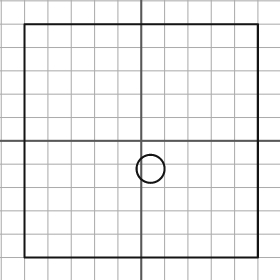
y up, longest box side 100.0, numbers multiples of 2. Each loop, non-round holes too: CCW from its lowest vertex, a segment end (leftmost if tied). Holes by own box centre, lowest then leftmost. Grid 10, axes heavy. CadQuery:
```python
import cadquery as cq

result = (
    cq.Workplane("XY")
    .moveTo(-50.0, -50.0)
    .lineTo(50.0, -50.0)
    .lineTo(50.0, 50.0)
    .lineTo(-50.0, 50.0)
    .close()
    .moveTo(4.0, -12.0)
    .circle(6.0)
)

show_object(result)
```